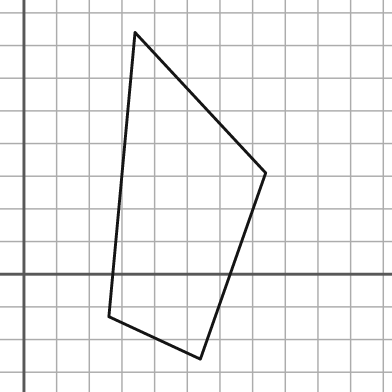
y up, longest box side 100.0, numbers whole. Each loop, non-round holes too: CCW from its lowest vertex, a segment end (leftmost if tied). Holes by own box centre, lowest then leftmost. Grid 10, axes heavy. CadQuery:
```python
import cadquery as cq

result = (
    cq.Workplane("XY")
    .moveTo(54.0, -26.0)
    .lineTo(74.0, 31.0)
    .lineTo(34.0, 74.0)
    .lineTo(26.0, -13.0)
    .close()
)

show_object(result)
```